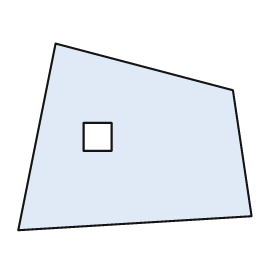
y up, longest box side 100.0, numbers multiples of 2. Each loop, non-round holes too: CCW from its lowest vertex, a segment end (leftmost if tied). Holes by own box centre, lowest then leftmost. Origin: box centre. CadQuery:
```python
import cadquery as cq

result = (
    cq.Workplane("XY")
    .moveTo(-50.0, -40.0)
    .lineTo(50.0, -34.0)
    .lineTo(42.0, 20.0)
    .lineTo(-34.0, 40.0)
    .close()
    .moveTo(-22.0, -6.0)
    .lineTo(-10.0, -6.0)
    .lineTo(-10.0, 6.0)
    .lineTo(-22.0, 6.0)
    .close()
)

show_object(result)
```